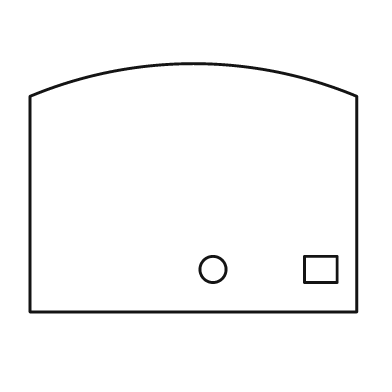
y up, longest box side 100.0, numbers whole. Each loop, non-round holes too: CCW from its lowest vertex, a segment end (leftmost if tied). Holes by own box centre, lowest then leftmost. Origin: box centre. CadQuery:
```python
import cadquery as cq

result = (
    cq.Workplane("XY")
    .moveTo(-50.0, -38.0)
    .lineTo(50.0, -38.0)
    .lineTo(50.0, 28.0)
    .threePointArc((0.0, 38.0), (-50.0, 28.0))
    .close()
    .moveTo(6.0, -25.0)
    .circle(4.0)
    .moveTo(34.0, -29.0)
    .lineTo(44.0, -29.0)
    .lineTo(44.0, -21.0)
    .lineTo(34.0, -21.0)
    .close()
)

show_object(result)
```